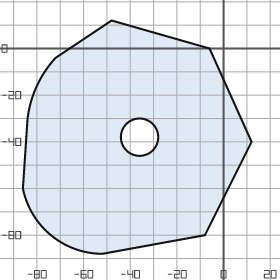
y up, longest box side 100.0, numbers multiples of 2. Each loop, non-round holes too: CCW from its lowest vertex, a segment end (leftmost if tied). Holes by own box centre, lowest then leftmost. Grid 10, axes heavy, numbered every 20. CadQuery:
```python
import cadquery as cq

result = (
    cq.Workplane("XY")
    .moveTo(-52.0, -88.0)
    .lineTo(-8.0, -80.0)
    .lineTo(12.0, -40.0)
    .lineTo(-6.0, 0.0)
    .lineTo(-48.0, 12.0)
    .lineTo(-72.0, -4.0)
    .threePointArc((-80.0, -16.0), (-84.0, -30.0))
    .lineTo(-86.0, -60.0)
    .threePointArc((-74.0, -80.0), (-52.0, -88.0))
    .close()
    .moveTo(-36.0, -38.0)
    .circle(8.0)
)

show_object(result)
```